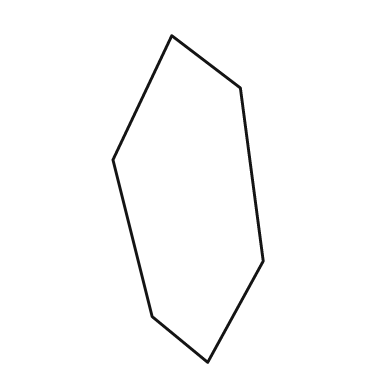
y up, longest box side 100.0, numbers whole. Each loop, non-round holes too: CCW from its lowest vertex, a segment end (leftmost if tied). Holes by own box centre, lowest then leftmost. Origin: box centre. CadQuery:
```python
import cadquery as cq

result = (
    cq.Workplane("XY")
    .moveTo(6.0, -50.0)
    .lineTo(23.0, -19.0)
    .lineTo(16.0, 34.0)
    .lineTo(-5.0, 50.0)
    .lineTo(-23.0, 12.0)
    .lineTo(-11.0, -36.0)
    .close()
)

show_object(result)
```